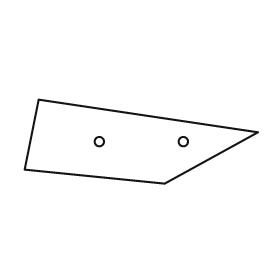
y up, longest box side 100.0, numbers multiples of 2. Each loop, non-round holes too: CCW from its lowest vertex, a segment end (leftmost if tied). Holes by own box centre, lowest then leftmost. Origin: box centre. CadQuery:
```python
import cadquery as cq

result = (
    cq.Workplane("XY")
    .moveTo(10.0, -18.0)
    .lineTo(50.0, 4.0)
    .lineTo(-44.0, 18.0)
    .lineTo(-50.0, -12.0)
    .close()
    .moveTo(-18.0, 0.0)
    .circle(2.0)
    .moveTo(18.0, 0.0)
    .circle(2.0)
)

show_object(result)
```